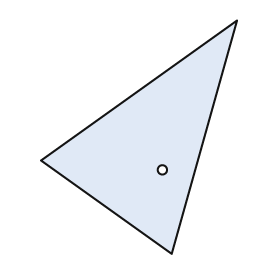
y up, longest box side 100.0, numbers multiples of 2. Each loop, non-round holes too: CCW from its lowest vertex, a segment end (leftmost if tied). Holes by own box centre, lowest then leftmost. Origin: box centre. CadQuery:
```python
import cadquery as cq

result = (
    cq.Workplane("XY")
    .moveTo(14.0, -50.0)
    .lineTo(42.0, 50.0)
    .lineTo(-42.0, -10.0)
    .close()
    .moveTo(10.0, -14.0)
    .circle(2.0)
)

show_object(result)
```